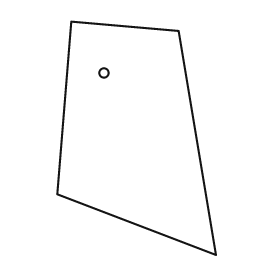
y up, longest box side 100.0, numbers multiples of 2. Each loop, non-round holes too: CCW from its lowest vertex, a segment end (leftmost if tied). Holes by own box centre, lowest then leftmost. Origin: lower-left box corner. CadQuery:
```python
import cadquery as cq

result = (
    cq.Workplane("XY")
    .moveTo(68.0, 0.0)
    .lineTo(52.0, 96.0)
    .lineTo(6.0, 100.0)
    .lineTo(0.0, 26.0)
    .close()
    .moveTo(20.0, 78.0)
    .circle(2.0)
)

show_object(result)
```